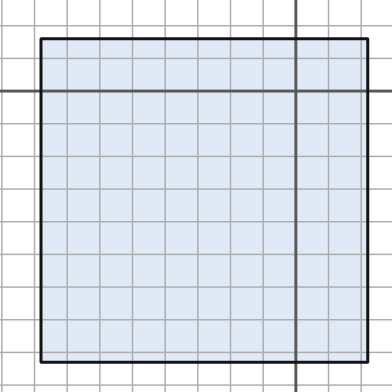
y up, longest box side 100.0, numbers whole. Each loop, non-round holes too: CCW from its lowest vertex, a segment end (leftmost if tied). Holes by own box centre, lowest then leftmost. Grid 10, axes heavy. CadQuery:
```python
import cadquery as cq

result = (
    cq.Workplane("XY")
    .moveTo(-78.0, -83.0)
    .lineTo(22.0, -83.0)
    .lineTo(22.0, 16.0)
    .lineTo(-78.0, 16.0)
    .close()
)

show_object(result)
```